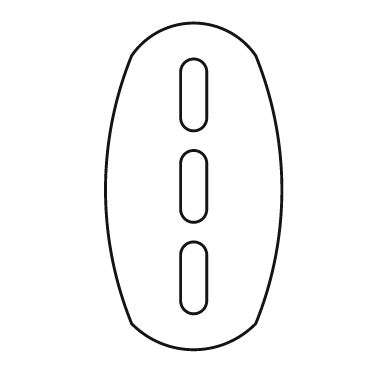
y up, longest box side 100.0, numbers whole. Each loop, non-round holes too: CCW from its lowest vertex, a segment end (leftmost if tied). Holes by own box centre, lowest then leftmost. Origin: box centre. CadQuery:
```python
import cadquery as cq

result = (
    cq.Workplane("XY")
    .moveTo(-19.0, -42.0)
    .threePointArc((0.0, -50.0), (19.0, -42.0))
    .threePointArc((27.0, -1.0), (19.0, 40.0))
    .threePointArc((0.0, 50.0), (-19.0, 40.0))
    .threePointArc((-27.0, -1.0), (-19.0, -42.0))
    .close()
    .moveTo(-4.0, -35.0)
    .threePointArc((0.0, -39.0), (4.0, -35.0))
    .lineTo(4.0, -21.0)
    .threePointArc((0.0, -17.0), (-4.0, -21.0))
    .close()
    .moveTo(-4.0, -7.0)
    .threePointArc((0.0, -11.0), (4.0, -7.0))
    .lineTo(4.0, 7.0)
    .threePointArc((0.0, 11.0), (-4.0, 7.0))
    .close()
    .moveTo(-4.0, 21.0)
    .threePointArc((0.0, 17.0), (4.0, 21.0))
    .lineTo(4.0, 35.0)
    .threePointArc((0.0, 39.0), (-4.0, 35.0))
    .close()
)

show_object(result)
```